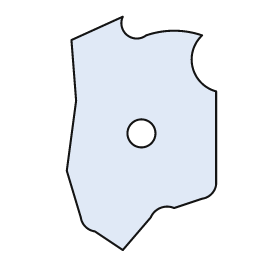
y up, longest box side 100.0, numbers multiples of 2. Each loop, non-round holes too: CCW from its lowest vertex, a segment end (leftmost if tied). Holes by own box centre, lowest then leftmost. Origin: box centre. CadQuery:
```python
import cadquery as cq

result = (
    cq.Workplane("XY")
    .moveTo(-8.0, -50.0)
    .lineTo(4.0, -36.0)
    .threePointArc((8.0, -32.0), (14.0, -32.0))
    .lineTo(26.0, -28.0)
    .threePointArc((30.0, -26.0), (32.0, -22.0))
    .lineTo(32.0, 18.0)
    .threePointArc((22.0, 28.0), (26.0, 42.0))
    .threePointArc((14.0, 44.0), (2.0, 42.0))
    .threePointArc((-6.0, 42.0), (-8.0, 50.0))
    .lineTo(-30.0, 40.0)
    .lineTo(-28.0, 14.0)
    .lineTo(-32.0, -16.0)
    .lineTo(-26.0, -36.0)
    .threePointArc((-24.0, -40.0), (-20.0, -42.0))
    .close()
    .moveTo(0.0, 0.0)
    .circle(6.0)
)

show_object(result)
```